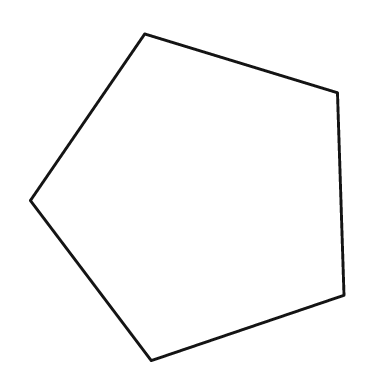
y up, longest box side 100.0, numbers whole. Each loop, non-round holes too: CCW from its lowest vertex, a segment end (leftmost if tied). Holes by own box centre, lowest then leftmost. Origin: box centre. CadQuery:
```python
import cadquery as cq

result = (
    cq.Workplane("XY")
    .moveTo(-11.0, -50.0)
    .lineTo(48.0, -30.0)
    .lineTo(46.0, 32.0)
    .lineTo(-13.0, 50.0)
    .lineTo(-48.0, -1.0)
    .close()
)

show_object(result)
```